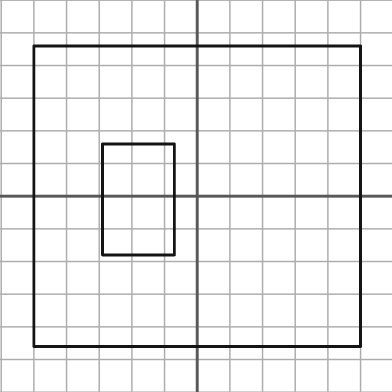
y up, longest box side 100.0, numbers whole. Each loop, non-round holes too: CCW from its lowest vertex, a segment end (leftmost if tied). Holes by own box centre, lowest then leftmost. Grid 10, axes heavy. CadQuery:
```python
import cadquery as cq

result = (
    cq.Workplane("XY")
    .moveTo(-50.0, -46.0)
    .lineTo(50.0, -46.0)
    .lineTo(50.0, 46.0)
    .lineTo(-50.0, 46.0)
    .close()
    .moveTo(-29.0, -18.0)
    .lineTo(-7.0, -18.0)
    .lineTo(-7.0, 16.0)
    .lineTo(-29.0, 16.0)
    .close()
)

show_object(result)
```